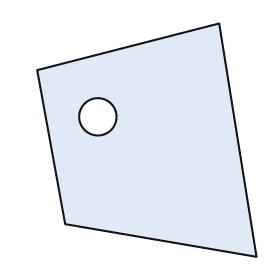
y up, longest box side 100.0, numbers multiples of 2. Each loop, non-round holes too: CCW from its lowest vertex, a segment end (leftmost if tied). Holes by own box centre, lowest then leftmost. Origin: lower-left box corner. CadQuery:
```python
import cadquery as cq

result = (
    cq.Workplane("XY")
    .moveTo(94.0, 0.0)
    .lineTo(78.0, 100.0)
    .lineTo(0.0, 80.0)
    .lineTo(12.0, 14.0)
    .close()
    .moveTo(26.0, 60.0)
    .circle(8.0)
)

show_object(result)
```